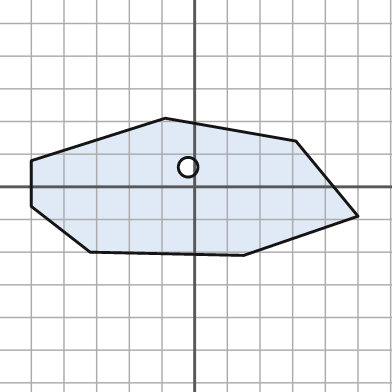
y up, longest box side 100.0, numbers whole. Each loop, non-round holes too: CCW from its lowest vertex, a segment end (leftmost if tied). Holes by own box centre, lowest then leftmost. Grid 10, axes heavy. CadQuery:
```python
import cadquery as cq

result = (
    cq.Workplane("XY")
    .moveTo(15.0, -21.0)
    .lineTo(50.0, -9.0)
    .lineTo(31.0, 14.0)
    .lineTo(-9.0, 21.0)
    .lineTo(-50.0, 8.0)
    .lineTo(-50.0, -6.0)
    .lineTo(-32.0, -20.0)
    .close()
    .moveTo(-2.0, 6.0)
    .circle(3.0)
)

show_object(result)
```